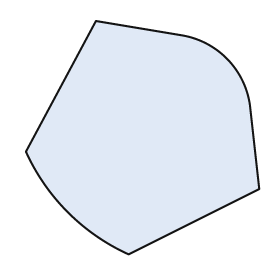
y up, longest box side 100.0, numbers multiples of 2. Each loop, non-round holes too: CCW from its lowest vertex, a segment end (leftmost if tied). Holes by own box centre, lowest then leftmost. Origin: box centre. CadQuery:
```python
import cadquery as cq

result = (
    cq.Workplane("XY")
    .moveTo(-6.0, -50.0)
    .lineTo(50.0, -22.0)
    .lineTo(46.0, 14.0)
    .threePointArc((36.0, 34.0), (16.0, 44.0))
    .lineTo(-20.0, 50.0)
    .lineTo(-50.0, -6.0)
    .threePointArc((-32.0, -32.0), (-6.0, -50.0))
    .close()
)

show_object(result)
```